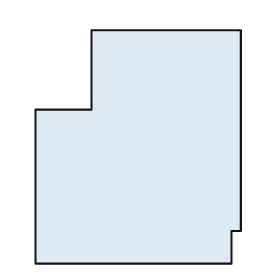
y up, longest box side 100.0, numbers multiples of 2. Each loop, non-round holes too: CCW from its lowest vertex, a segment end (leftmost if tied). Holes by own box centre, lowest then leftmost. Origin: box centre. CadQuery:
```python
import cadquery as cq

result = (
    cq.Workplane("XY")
    .moveTo(-44.0, -50.0)
    .lineTo(40.0, -50.0)
    .lineTo(40.0, -36.0)
    .lineTo(44.0, -36.0)
    .lineTo(44.0, 50.0)
    .lineTo(-20.0, 50.0)
    .lineTo(-20.0, 16.0)
    .lineTo(-44.0, 16.0)
    .close()
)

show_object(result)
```